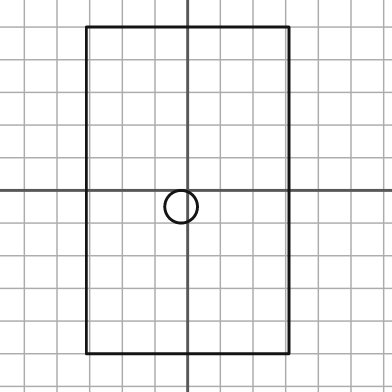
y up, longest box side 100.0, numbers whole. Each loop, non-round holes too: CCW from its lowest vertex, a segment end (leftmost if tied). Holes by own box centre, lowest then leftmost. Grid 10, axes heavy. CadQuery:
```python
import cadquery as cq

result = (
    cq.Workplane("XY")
    .moveTo(-31.0, -50.0)
    .lineTo(31.0, -50.0)
    .lineTo(31.0, 50.0)
    .lineTo(-31.0, 50.0)
    .close()
    .moveTo(-2.0, -5.0)
    .circle(5.0)
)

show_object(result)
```